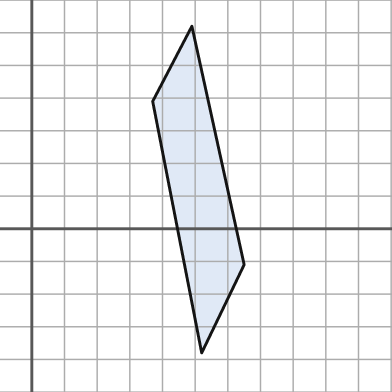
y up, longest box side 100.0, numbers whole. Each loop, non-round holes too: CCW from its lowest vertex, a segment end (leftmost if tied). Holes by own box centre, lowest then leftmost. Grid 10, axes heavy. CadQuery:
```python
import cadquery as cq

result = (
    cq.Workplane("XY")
    .moveTo(52.0, -38.0)
    .lineTo(65.0, -11.0)
    .lineTo(49.0, 62.0)
    .lineTo(37.0, 39.0)
    .close()
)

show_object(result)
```